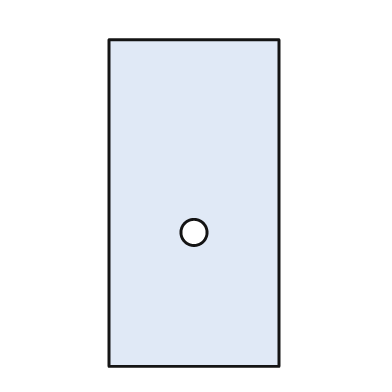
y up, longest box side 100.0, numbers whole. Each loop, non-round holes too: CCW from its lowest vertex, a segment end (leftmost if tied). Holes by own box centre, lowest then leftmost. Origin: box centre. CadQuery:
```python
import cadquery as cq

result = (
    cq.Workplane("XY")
    .moveTo(-26.0, -50.0)
    .lineTo(26.0, -50.0)
    .lineTo(26.0, 50.0)
    .lineTo(-26.0, 50.0)
    .close()
    .moveTo(0.0, -9.0)
    .circle(4.0)
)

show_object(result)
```